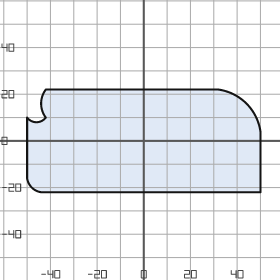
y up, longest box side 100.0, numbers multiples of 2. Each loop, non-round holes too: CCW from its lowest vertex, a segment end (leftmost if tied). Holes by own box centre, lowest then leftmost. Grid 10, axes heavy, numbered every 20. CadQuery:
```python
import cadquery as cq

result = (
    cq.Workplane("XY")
    .moveTo(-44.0, -22.0)
    .lineTo(50.0, -22.0)
    .lineTo(50.0, 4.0)
    .threePointArc((44.0, 16.0), (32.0, 22.0))
    .lineTo(-42.0, 22.0)
    .threePointArc((-44.0, 16.0), (-42.0, 10.0))
    .threePointArc((-46.0, 8.0), (-50.0, 10.0))
    .lineTo(-50.0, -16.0)
    .threePointArc((-48.0, -20.0), (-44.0, -22.0))
    .close()
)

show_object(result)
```